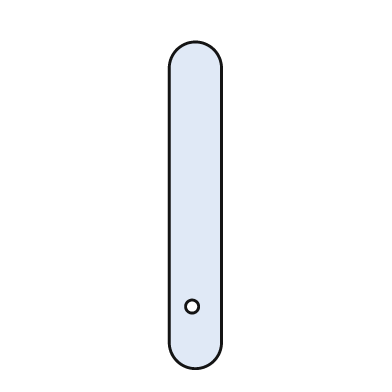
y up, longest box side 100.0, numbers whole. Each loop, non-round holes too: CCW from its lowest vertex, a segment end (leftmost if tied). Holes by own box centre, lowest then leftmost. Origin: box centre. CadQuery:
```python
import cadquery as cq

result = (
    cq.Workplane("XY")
    .moveTo(-8.0, -42.0)
    .threePointArc((0.0, -50.0), (8.0, -42.0))
    .lineTo(8.0, 42.0)
    .threePointArc((0.0, 50.0), (-8.0, 42.0))
    .close()
    .moveTo(-1.0, -31.0)
    .circle(2.0)
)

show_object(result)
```